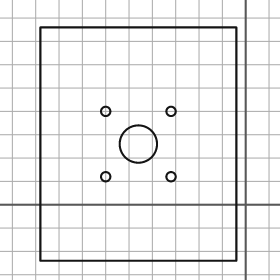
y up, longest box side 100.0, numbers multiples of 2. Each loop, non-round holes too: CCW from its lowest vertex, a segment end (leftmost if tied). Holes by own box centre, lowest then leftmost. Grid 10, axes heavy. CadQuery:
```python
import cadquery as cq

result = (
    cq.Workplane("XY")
    .moveTo(-88.0, -24.0)
    .lineTo(-4.0, -24.0)
    .lineTo(-4.0, 76.0)
    .lineTo(-88.0, 76.0)
    .close()
    .moveTo(-60.0, 12.0)
    .circle(2.0)
    .moveTo(-32.0, 12.0)
    .circle(2.0)
    .moveTo(-46.0, 26.0)
    .circle(8.0)
    .moveTo(-60.0, 40.0)
    .circle(2.0)
    .moveTo(-32.0, 40.0)
    .circle(2.0)
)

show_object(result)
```